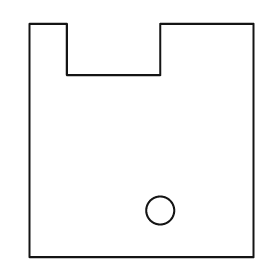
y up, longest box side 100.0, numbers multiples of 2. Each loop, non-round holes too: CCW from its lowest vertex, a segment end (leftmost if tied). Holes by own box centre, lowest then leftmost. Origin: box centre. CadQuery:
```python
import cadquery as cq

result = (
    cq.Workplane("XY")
    .moveTo(-48.0, -50.0)
    .lineTo(48.0, -50.0)
    .lineTo(48.0, 50.0)
    .lineTo(8.0, 50.0)
    .lineTo(8.0, 28.0)
    .lineTo(-32.0, 28.0)
    .lineTo(-32.0, 50.0)
    .lineTo(-48.0, 50.0)
    .close()
    .moveTo(8.0, -30.0)
    .circle(6.0)
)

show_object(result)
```